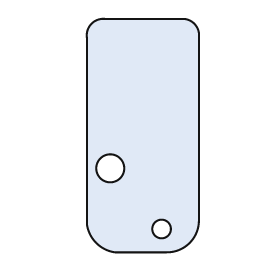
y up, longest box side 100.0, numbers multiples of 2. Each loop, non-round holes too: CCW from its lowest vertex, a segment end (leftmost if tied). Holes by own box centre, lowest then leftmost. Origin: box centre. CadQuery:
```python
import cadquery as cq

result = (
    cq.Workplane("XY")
    .moveTo(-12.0, -50.0)
    .lineTo(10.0, -50.0)
    .threePointArc((20.0, -46.0), (24.0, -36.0))
    .lineTo(24.0, 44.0)
    .threePointArc((22.0, 48.0), (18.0, 50.0))
    .lineTo(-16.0, 50.0)
    .threePointArc((-22.0, 48.0), (-24.0, 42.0))
    .lineTo(-24.0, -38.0)
    .threePointArc((-20.0, -46.0), (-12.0, -50.0))
    .close()
    .moveTo(8.0, -40.0)
    .circle(4.0)
    .moveTo(-14.0, -14.0)
    .circle(6.0)
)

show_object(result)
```